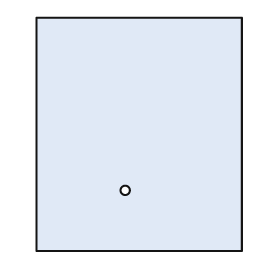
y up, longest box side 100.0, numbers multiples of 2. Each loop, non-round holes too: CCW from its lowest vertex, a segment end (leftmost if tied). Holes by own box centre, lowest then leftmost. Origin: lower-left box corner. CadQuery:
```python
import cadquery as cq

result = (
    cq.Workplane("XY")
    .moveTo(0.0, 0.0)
    .lineTo(88.0, 0.0)
    .lineTo(88.0, 100.0)
    .lineTo(0.0, 100.0)
    .close()
    .moveTo(38.0, 26.0)
    .circle(2.0)
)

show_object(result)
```